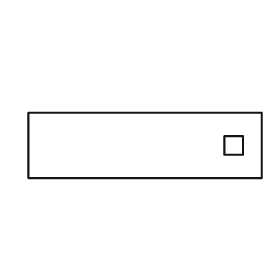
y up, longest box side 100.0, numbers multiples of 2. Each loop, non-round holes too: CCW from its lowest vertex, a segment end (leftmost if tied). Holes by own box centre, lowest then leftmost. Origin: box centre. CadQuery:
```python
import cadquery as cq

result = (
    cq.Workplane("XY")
    .moveTo(-50.0, -14.0)
    .lineTo(50.0, -14.0)
    .lineTo(50.0, 14.0)
    .lineTo(-50.0, 14.0)
    .close()
    .moveTo(34.0, -4.0)
    .lineTo(42.0, -4.0)
    .lineTo(42.0, 4.0)
    .lineTo(34.0, 4.0)
    .close()
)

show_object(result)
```